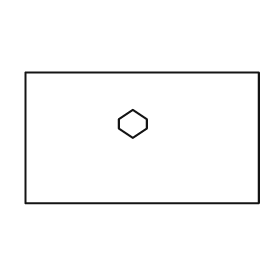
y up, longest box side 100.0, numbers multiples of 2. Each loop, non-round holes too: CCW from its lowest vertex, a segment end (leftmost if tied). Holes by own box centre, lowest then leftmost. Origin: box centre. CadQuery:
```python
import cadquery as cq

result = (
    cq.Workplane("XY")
    .moveTo(-50.0, -28.0)
    .lineTo(50.0, -28.0)
    .lineTo(50.0, 28.0)
    .lineTo(-50.0, 28.0)
    .close()
    .moveTo(-4.0, 0.0)
    .lineTo(2.0, 4.0)
    .lineTo(2.0, 8.0)
    .lineTo(-4.0, 12.0)
    .lineTo(-10.0, 8.0)
    .lineTo(-10.0, 4.0)
    .close()
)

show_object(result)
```